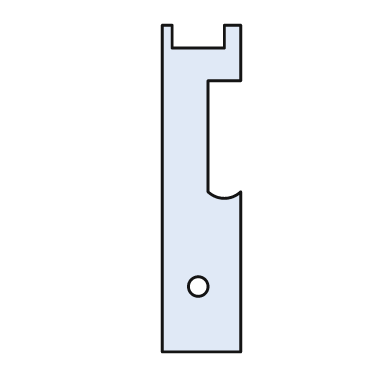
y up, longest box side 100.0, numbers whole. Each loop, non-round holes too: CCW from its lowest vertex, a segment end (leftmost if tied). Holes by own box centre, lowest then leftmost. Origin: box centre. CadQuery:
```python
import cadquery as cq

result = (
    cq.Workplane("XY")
    .moveTo(-12.0, -50.0)
    .lineTo(12.0, -50.0)
    .lineTo(12.0, -1.0)
    .threePointArc((7.0, -3.0), (2.0, -1.0))
    .lineTo(2.0, 33.0)
    .lineTo(12.0, 33.0)
    .lineTo(12.0, 50.0)
    .lineTo(7.0, 50.0)
    .lineTo(7.0, 43.0)
    .lineTo(-9.0, 43.0)
    .lineTo(-9.0, 50.0)
    .lineTo(-12.0, 50.0)
    .close()
    .moveTo(-1.0, -30.0)
    .circle(3.0)
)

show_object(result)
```